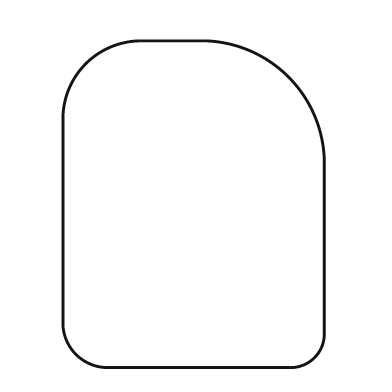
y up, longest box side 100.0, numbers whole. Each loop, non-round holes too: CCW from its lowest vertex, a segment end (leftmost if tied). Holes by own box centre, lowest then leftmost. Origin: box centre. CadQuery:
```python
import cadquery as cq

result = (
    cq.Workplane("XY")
    .moveTo(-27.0, -50.0)
    .lineTo(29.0, -50.0)
    .threePointArc((37.0, -47.0), (40.0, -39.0))
    .lineTo(40.0, 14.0)
    .threePointArc((29.0, 39.0), (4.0, 50.0))
    .lineTo(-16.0, 50.0)
    .threePointArc((-33.0, 43.0), (-40.0, 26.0))
    .lineTo(-40.0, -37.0)
    .threePointArc((-36.0, -46.0), (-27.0, -50.0))
    .close()
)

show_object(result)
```